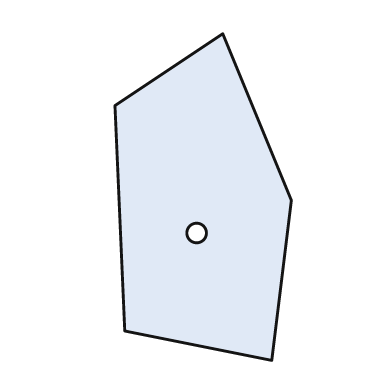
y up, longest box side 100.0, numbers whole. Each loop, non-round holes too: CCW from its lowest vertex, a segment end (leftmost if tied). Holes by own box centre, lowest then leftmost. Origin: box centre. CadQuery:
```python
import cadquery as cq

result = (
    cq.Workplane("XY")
    .moveTo(21.0, -50.0)
    .lineTo(27.0, -1.0)
    .lineTo(6.0, 50.0)
    .lineTo(-27.0, 28.0)
    .lineTo(-24.0, -41.0)
    .close()
    .moveTo(-2.0, -11.0)
    .circle(3.0)
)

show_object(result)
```